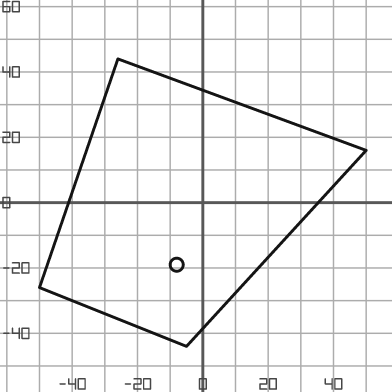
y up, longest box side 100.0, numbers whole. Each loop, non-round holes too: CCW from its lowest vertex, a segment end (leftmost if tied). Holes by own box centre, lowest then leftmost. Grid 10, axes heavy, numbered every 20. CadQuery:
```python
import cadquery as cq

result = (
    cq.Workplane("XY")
    .moveTo(-5.0, -44.0)
    .lineTo(50.0, 16.0)
    .lineTo(-26.0, 44.0)
    .lineTo(-50.0, -26.0)
    .close()
    .moveTo(-8.0, -19.0)
    .circle(2.0)
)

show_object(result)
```